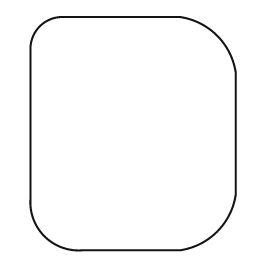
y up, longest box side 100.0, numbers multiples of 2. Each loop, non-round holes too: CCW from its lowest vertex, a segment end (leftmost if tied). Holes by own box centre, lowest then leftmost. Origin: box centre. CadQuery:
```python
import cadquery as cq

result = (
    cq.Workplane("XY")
    .moveTo(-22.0, -50.0)
    .lineTo(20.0, -50.0)
    .threePointArc((36.0, -42.0), (44.0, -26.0))
    .lineTo(44.0, 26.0)
    .threePointArc((36.0, 42.0), (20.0, 50.0))
    .lineTo(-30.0, 50.0)
    .threePointArc((-40.0, 46.0), (-44.0, 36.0))
    .lineTo(-44.0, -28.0)
    .threePointArc((-38.0, -44.0), (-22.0, -50.0))
    .close()
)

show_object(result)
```